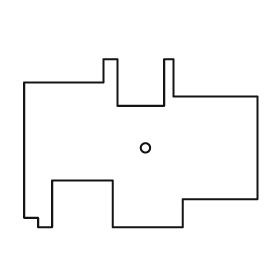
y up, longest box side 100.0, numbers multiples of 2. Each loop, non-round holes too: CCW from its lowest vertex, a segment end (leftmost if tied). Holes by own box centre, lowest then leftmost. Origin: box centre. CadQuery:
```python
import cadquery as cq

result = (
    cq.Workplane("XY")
    .moveTo(-44.0, -36.0)
    .lineTo(-38.0, -36.0)
    .lineTo(-38.0, -16.0)
    .lineTo(-12.0, -16.0)
    .lineTo(-12.0, -36.0)
    .lineTo(18.0, -36.0)
    .lineTo(18.0, -24.0)
    .lineTo(50.0, -24.0)
    .lineTo(50.0, 20.0)
    .lineTo(14.0, 20.0)
    .lineTo(14.0, 36.0)
    .lineTo(10.0, 36.0)
    .lineTo(10.0, 16.0)
    .lineTo(-10.0, 16.0)
    .lineTo(-10.0, 36.0)
    .lineTo(-16.0, 36.0)
    .lineTo(-16.0, 26.0)
    .lineTo(-50.0, 26.0)
    .lineTo(-50.0, -32.0)
    .lineTo(-44.0, -32.0)
    .close()
    .moveTo(2.0, -2.0)
    .circle(2.0)
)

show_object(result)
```